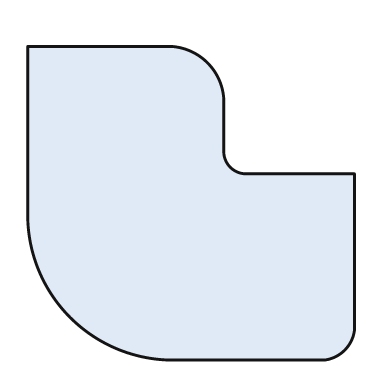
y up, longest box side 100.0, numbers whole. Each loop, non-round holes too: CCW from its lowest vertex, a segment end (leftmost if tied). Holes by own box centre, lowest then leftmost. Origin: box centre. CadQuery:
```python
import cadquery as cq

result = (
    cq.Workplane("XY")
    .moveTo(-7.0, -48.0)
    .lineTo(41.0, -48.0)
    .threePointArc((47.0, -45.0), (50.0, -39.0))
    .lineTo(50.0, 9.0)
    .lineTo(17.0, 9.0)
    .threePointArc((12.0, 11.0), (10.0, 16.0))
    .lineTo(10.0, 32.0)
    .threePointArc((5.0, 43.0), (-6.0, 48.0))
    .lineTo(-50.0, 48.0)
    .lineTo(-50.0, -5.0)
    .threePointArc((-37.0, -35.0), (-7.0, -48.0))
    .close()
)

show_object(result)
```